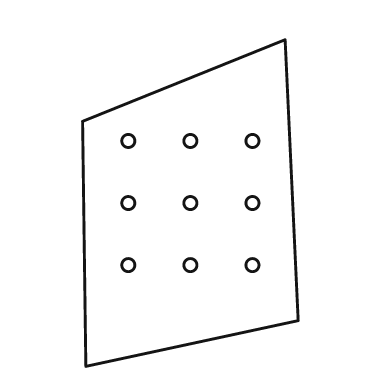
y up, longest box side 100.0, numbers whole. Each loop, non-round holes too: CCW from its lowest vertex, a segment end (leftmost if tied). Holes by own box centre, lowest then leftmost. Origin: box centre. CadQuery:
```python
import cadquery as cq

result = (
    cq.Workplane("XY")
    .moveTo(-32.0, -50.0)
    .lineTo(33.0, -36.0)
    .lineTo(29.0, 50.0)
    .lineTo(-33.0, 25.0)
    .close()
    .moveTo(-19.0, -19.0)
    .circle(2.0)
    .moveTo(0.0, -19.0)
    .circle(2.0)
    .moveTo(19.0, -19.0)
    .circle(2.0)
    .moveTo(-19.0, 0.0)
    .circle(2.0)
    .moveTo(0.0, 0.0)
    .circle(2.0)
    .moveTo(19.0, 0.0)
    .circle(2.0)
    .moveTo(-19.0, 19.0)
    .circle(2.0)
    .moveTo(0.0, 19.0)
    .circle(2.0)
    .moveTo(19.0, 19.0)
    .circle(2.0)
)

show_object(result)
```